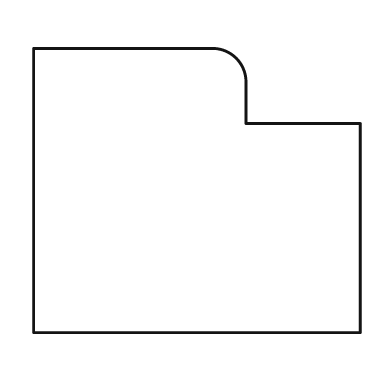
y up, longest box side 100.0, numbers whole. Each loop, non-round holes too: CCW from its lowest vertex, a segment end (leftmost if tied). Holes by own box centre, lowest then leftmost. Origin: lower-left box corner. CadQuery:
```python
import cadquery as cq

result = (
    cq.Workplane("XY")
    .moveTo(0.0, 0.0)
    .lineTo(100.0, 0.0)
    .lineTo(100.0, 64.0)
    .lineTo(65.0, 64.0)
    .lineTo(65.0, 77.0)
    .threePointArc((62.0, 84.0), (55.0, 87.0))
    .lineTo(0.0, 87.0)
    .close()
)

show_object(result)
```